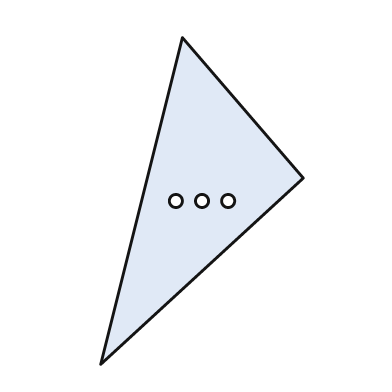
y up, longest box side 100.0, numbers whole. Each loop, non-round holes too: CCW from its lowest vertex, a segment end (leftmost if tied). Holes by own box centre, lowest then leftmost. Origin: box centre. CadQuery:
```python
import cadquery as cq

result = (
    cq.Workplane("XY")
    .moveTo(-31.0, -50.0)
    .lineTo(31.0, 7.0)
    .lineTo(-6.0, 50.0)
    .close()
    .moveTo(-8.0, 0.0)
    .circle(2.0)
    .moveTo(0.0, 0.0)
    .circle(2.0)
    .moveTo(8.0, 0.0)
    .circle(2.0)
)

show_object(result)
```